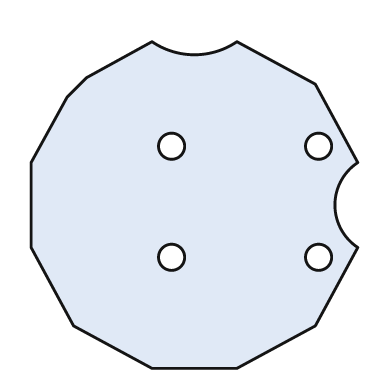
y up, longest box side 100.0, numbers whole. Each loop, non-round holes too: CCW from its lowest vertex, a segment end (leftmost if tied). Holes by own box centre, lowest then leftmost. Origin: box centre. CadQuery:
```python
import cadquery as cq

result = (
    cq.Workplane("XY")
    .moveTo(-13.0, -50.0)
    .lineTo(13.0, -50.0)
    .lineTo(37.0, -37.0)
    .lineTo(50.0, -13.0)
    .threePointArc((43.0, 0.0), (50.0, 13.0))
    .lineTo(37.0, 37.0)
    .lineTo(13.0, 50.0)
    .threePointArc((0.0, 46.0), (-13.0, 50.0))
    .lineTo(-33.0, 39.0)
    .lineTo(-39.0, 33.0)
    .lineTo(-50.0, 13.0)
    .lineTo(-50.0, -13.0)
    .lineTo(-37.0, -37.0)
    .close()
    .moveTo(-7.0, -16.0)
    .circle(4.0)
    .moveTo(38.0, -16.0)
    .circle(4.0)
    .moveTo(-7.0, 18.0)
    .circle(4.0)
    .moveTo(38.0, 18.0)
    .circle(4.0)
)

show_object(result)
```